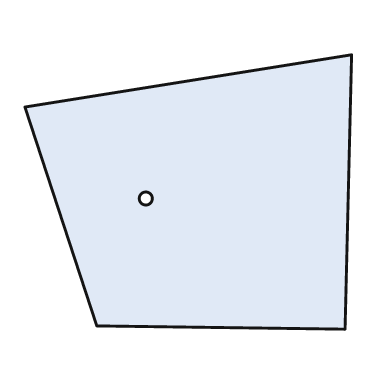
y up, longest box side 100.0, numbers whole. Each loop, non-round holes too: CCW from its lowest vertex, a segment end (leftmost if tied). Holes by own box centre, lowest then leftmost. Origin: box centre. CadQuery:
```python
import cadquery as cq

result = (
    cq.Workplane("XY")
    .moveTo(48.0, -42.0)
    .lineTo(50.0, 42.0)
    .lineTo(-50.0, 26.0)
    .lineTo(-28.0, -41.0)
    .close()
    .moveTo(-13.0, -2.0)
    .circle(2.0)
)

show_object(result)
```